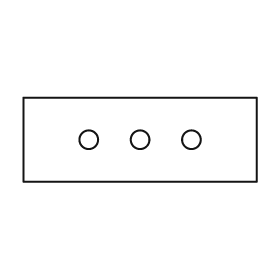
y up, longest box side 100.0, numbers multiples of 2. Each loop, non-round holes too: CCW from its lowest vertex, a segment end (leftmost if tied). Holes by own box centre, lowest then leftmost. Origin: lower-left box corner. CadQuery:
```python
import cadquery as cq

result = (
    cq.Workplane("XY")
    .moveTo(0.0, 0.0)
    .lineTo(100.0, 0.0)
    .lineTo(100.0, 36.0)
    .lineTo(0.0, 36.0)
    .close()
    .moveTo(28.0, 18.0)
    .circle(4.0)
    .moveTo(50.0, 18.0)
    .circle(4.0)
    .moveTo(72.0, 18.0)
    .circle(4.0)
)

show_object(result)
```